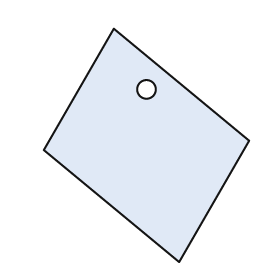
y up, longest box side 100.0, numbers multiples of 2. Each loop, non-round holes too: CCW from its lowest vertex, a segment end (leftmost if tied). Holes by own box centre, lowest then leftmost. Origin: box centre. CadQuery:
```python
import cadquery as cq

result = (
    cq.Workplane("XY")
    .moveTo(14.0, -50.0)
    .lineTo(44.0, 2.0)
    .lineTo(-14.0, 50.0)
    .lineTo(-44.0, -2.0)
    .close()
    .moveTo(0.0, 24.0)
    .circle(4.0)
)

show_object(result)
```